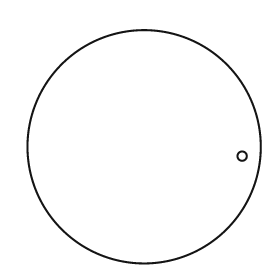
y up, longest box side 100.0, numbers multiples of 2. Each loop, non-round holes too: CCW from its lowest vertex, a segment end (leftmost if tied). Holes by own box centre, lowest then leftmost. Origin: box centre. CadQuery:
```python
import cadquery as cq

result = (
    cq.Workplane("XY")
    .moveTo(0.0, 0.0)
    .circle(50.0)
    .moveTo(42.0, -4.0)
    .circle(2.0)
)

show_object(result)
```